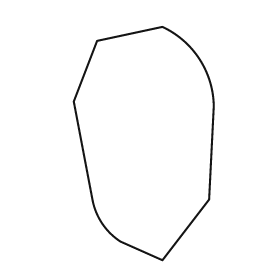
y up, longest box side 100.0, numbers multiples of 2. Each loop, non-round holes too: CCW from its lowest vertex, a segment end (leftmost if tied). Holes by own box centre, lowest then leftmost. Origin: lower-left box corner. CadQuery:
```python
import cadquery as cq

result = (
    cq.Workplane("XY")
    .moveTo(38.0, 0.0)
    .lineTo(58.0, 26.0)
    .lineTo(60.0, 66.0)
    .threePointArc((54.0, 86.0), (38.0, 100.0))
    .lineTo(10.0, 94.0)
    .lineTo(0.0, 68.0)
    .lineTo(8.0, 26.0)
    .threePointArc((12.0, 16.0), (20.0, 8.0))
    .close()
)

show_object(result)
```